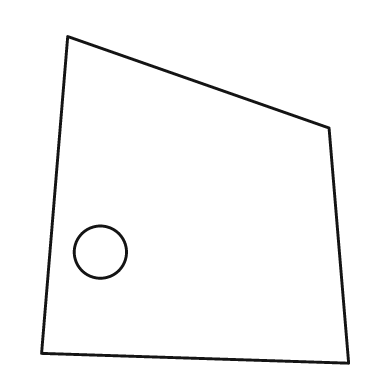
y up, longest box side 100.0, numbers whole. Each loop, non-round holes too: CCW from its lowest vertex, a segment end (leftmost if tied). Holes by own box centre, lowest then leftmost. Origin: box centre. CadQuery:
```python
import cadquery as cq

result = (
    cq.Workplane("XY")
    .moveTo(47.0, -50.0)
    .lineTo(41.0, 22.0)
    .lineTo(-39.0, 50.0)
    .lineTo(-47.0, -47.0)
    .close()
    .moveTo(-29.0, -16.0)
    .circle(8.0)
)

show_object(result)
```